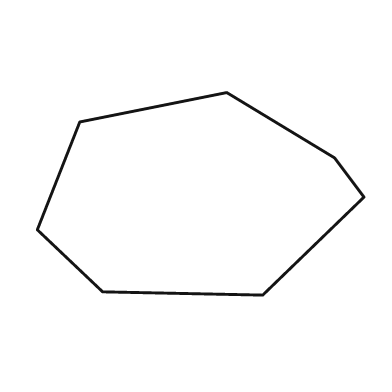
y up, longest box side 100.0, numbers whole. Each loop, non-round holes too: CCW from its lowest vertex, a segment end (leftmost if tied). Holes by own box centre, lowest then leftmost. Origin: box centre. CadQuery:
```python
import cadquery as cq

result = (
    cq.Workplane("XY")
    .moveTo(19.0, -31.0)
    .lineTo(50.0, -1.0)
    .lineTo(41.0, 11.0)
    .lineTo(8.0, 31.0)
    .lineTo(-37.0, 22.0)
    .lineTo(-50.0, -11.0)
    .lineTo(-30.0, -30.0)
    .close()
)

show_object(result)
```